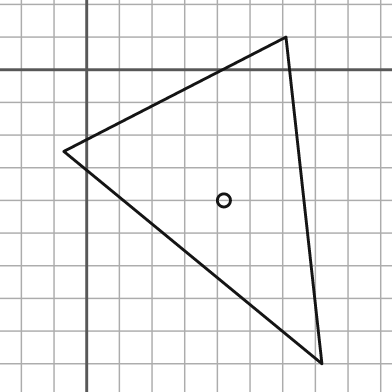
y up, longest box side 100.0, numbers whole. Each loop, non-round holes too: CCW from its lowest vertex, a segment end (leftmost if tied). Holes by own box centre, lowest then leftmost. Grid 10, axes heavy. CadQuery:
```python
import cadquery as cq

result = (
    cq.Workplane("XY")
    .moveTo(72.0, -90.0)
    .lineTo(61.0, 10.0)
    .lineTo(-7.0, -25.0)
    .close()
    .moveTo(42.0, -40.0)
    .circle(2.0)
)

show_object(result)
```